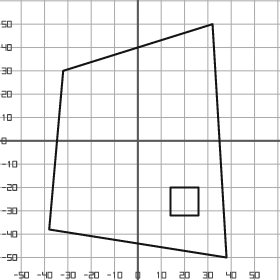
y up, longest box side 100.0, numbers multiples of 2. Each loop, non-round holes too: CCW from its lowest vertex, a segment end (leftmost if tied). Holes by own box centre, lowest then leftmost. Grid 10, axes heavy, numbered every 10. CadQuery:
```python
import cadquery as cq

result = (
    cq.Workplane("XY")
    .moveTo(38.0, -50.0)
    .lineTo(32.0, 50.0)
    .lineTo(-32.0, 30.0)
    .lineTo(-38.0, -38.0)
    .close()
    .moveTo(14.0, -32.0)
    .lineTo(26.0, -32.0)
    .lineTo(26.0, -20.0)
    .lineTo(14.0, -20.0)
    .close()
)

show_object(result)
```